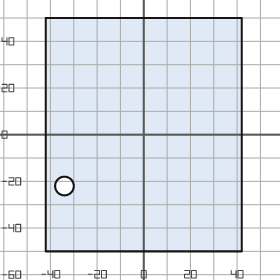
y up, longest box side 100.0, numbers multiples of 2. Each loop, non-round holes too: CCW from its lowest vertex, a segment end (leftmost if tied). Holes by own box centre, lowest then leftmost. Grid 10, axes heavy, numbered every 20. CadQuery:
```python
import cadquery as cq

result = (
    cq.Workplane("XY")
    .moveTo(-42.0, -50.0)
    .lineTo(42.0, -50.0)
    .lineTo(42.0, 50.0)
    .lineTo(-42.0, 50.0)
    .close()
    .moveTo(-34.0, -22.0)
    .circle(4.0)
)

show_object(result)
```